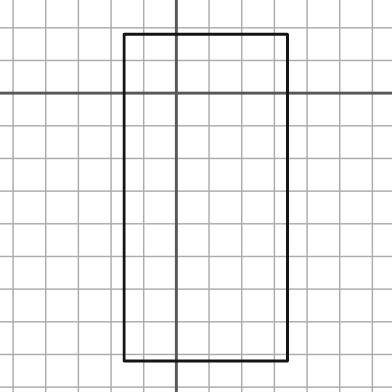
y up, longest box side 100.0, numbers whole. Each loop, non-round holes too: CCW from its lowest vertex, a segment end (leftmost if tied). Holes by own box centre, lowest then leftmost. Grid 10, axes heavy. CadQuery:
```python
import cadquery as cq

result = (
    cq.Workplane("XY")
    .moveTo(-16.0, -82.0)
    .lineTo(34.0, -82.0)
    .lineTo(34.0, 18.0)
    .lineTo(-16.0, 18.0)
    .close()
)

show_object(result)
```